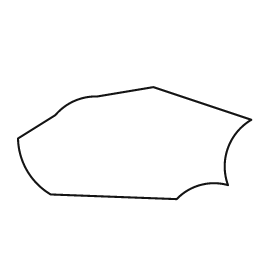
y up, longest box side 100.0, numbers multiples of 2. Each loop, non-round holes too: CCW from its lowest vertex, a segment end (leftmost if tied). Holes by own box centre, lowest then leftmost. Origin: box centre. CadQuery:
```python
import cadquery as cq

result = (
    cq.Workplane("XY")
    .moveTo(18.0, -24.0)
    .threePointArc((28.0, -18.0), (40.0, -18.0))
    .threePointArc((40.0, -2.0), (50.0, 10.0))
    .lineTo(8.0, 24.0)
    .lineTo(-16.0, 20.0)
    .threePointArc((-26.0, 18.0), (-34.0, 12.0))
    .lineTo(-50.0, 2.0)
    .threePointArc((-46.0, -12.0), (-36.0, -22.0))
    .close()
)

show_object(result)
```